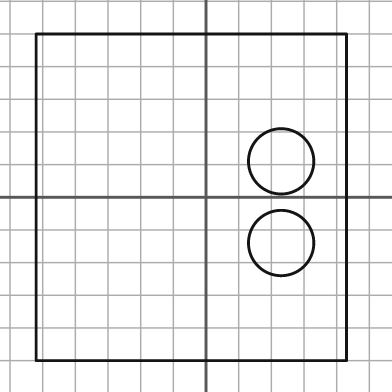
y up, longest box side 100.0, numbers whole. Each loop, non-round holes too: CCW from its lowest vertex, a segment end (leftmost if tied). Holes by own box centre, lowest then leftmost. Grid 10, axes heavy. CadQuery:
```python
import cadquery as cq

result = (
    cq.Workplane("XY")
    .moveTo(-52.0, -50.0)
    .lineTo(43.0, -50.0)
    .lineTo(43.0, 50.0)
    .lineTo(-52.0, 50.0)
    .close()
    .moveTo(23.0, -14.0)
    .circle(10.0)
    .moveTo(23.0, 11.0)
    .circle(10.0)
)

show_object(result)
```